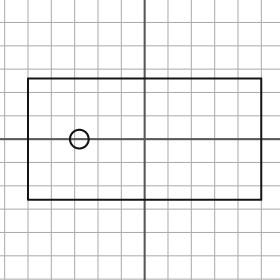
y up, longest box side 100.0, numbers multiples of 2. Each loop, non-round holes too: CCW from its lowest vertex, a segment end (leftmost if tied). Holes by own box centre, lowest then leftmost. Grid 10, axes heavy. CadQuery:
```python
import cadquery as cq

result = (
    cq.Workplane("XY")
    .moveTo(-50.0, -26.0)
    .lineTo(50.0, -26.0)
    .lineTo(50.0, 26.0)
    .lineTo(-50.0, 26.0)
    .close()
    .moveTo(-28.0, 0.0)
    .circle(4.0)
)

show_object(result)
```